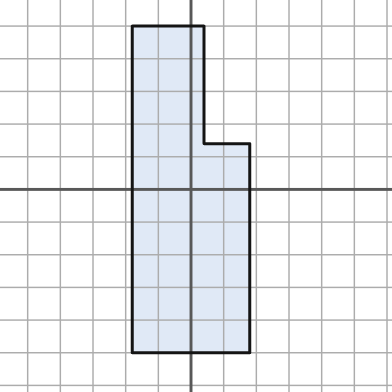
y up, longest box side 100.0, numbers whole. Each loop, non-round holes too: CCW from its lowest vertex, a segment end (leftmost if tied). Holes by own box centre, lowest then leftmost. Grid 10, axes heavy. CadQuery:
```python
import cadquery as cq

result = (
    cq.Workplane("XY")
    .moveTo(-18.0, -50.0)
    .lineTo(18.0, -50.0)
    .lineTo(18.0, 14.0)
    .lineTo(4.0, 14.0)
    .lineTo(4.0, 50.0)
    .lineTo(-18.0, 50.0)
    .close()
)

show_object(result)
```